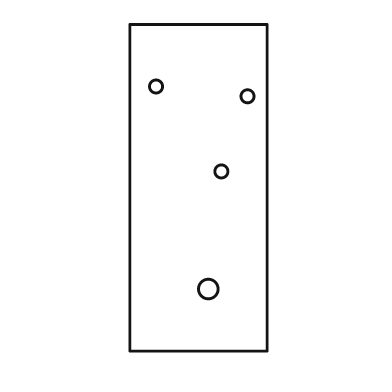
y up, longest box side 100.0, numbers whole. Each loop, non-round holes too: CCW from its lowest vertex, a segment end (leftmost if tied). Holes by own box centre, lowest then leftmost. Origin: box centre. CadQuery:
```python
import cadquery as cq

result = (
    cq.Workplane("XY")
    .moveTo(-21.0, -50.0)
    .lineTo(21.0, -50.0)
    .lineTo(21.0, 50.0)
    .lineTo(-21.0, 50.0)
    .close()
    .moveTo(3.0, -31.0)
    .circle(3.0)
    .moveTo(7.0, 5.0)
    .circle(2.0)
    .moveTo(15.0, 28.0)
    .circle(2.0)
    .moveTo(-13.0, 31.0)
    .circle(2.0)
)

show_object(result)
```